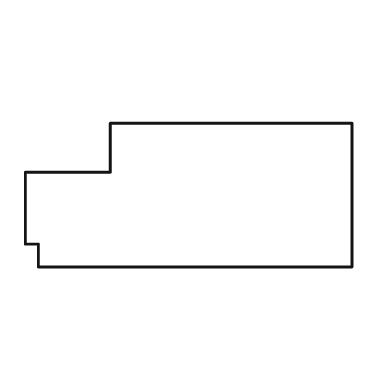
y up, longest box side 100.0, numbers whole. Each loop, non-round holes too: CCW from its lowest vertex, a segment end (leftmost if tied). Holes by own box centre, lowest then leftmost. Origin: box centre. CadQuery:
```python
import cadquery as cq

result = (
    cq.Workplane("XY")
    .moveTo(-46.0, -22.0)
    .lineTo(50.0, -22.0)
    .lineTo(50.0, 22.0)
    .lineTo(-24.0, 22.0)
    .lineTo(-24.0, 7.0)
    .lineTo(-50.0, 7.0)
    .lineTo(-50.0, -15.0)
    .lineTo(-46.0, -15.0)
    .close()
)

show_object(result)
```